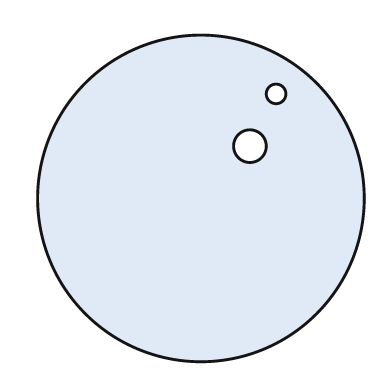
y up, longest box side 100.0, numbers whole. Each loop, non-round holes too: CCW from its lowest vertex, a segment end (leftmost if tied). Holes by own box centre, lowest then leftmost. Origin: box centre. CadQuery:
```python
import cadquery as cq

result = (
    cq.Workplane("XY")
    .moveTo(0.0, 0.0)
    .circle(50.0)
    .moveTo(15.0, 16.0)
    .circle(5.0)
    .moveTo(23.0, 32.0)
    .circle(3.0)
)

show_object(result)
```